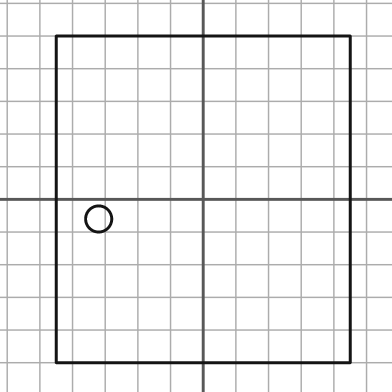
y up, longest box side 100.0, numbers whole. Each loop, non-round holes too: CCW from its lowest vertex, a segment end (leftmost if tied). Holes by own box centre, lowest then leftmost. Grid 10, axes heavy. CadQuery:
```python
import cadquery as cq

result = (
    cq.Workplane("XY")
    .moveTo(-45.0, -50.0)
    .lineTo(45.0, -50.0)
    .lineTo(45.0, 50.0)
    .lineTo(-45.0, 50.0)
    .close()
    .moveTo(-32.0, -6.0)
    .circle(4.0)
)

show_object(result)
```